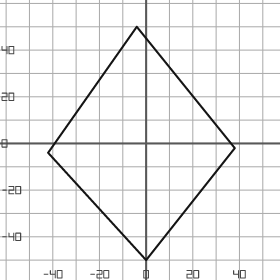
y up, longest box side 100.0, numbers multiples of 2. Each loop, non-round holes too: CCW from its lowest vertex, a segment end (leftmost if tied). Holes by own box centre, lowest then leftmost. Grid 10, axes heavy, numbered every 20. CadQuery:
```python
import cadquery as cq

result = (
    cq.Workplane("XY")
    .moveTo(0.0, -50.0)
    .lineTo(38.0, -2.0)
    .lineTo(-4.0, 50.0)
    .lineTo(-42.0, -4.0)
    .close()
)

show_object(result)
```